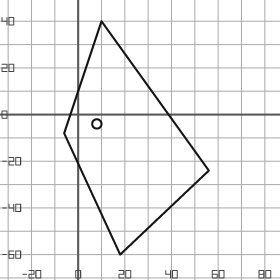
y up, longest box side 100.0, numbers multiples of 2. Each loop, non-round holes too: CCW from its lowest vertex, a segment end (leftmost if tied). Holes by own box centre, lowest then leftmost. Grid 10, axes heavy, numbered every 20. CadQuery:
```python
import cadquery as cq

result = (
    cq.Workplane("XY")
    .moveTo(18.0, -60.0)
    .lineTo(56.0, -24.0)
    .lineTo(10.0, 40.0)
    .lineTo(-6.0, -8.0)
    .close()
    .moveTo(8.0, -4.0)
    .circle(2.0)
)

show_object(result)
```